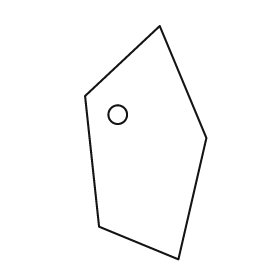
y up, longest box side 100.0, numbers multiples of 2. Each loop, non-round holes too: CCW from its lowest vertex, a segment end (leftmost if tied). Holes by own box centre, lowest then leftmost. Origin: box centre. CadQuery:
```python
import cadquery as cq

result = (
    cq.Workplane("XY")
    .moveTo(14.0, -50.0)
    .lineTo(26.0, 2.0)
    .lineTo(6.0, 50.0)
    .lineTo(-26.0, 20.0)
    .lineTo(-20.0, -36.0)
    .close()
    .moveTo(-12.0, 12.0)
    .circle(4.0)
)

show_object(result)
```